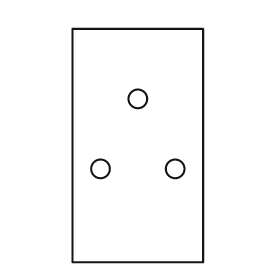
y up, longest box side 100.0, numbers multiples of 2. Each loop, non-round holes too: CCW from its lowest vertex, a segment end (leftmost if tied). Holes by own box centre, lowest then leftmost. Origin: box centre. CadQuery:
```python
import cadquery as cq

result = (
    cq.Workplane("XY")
    .moveTo(-28.0, -50.0)
    .lineTo(28.0, -50.0)
    .lineTo(28.0, 50.0)
    .lineTo(-28.0, 50.0)
    .close()
    .moveTo(-16.0, -10.0)
    .circle(4.0)
    .moveTo(16.0, -10.0)
    .circle(4.0)
    .moveTo(0.0, 20.0)
    .circle(4.0)
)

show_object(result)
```